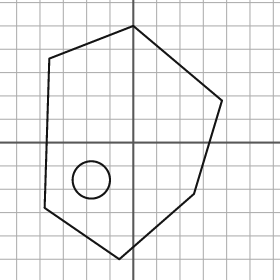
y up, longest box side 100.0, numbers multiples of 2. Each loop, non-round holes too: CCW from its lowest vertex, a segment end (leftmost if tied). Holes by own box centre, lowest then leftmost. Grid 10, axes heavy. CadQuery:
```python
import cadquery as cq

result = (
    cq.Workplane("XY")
    .moveTo(-6.0, -50.0)
    .lineTo(26.0, -22.0)
    .lineTo(38.0, 18.0)
    .lineTo(0.0, 50.0)
    .lineTo(-36.0, 36.0)
    .lineTo(-38.0, -28.0)
    .close()
    .moveTo(-18.0, -16.0)
    .circle(8.0)
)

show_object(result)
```